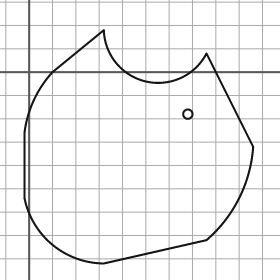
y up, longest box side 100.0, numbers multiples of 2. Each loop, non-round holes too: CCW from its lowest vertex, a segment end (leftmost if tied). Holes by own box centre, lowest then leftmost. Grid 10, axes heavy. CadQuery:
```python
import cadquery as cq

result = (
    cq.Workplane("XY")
    .moveTo(32.0, -82.0)
    .lineTo(76.0, -72.0)
    .threePointArc((90.0, -54.0), (96.0, -32.0))
    .lineTo(76.0, 8.0)
    .threePointArc((50.0, -4.0), (32.0, 18.0))
    .lineTo(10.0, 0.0)
    .threePointArc((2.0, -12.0), (-2.0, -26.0))
    .lineTo(-2.0, -54.0)
    .threePointArc((10.0, -74.0), (32.0, -82.0))
    .close()
    .moveTo(68.0, -18.0)
    .circle(2.0)
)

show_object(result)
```